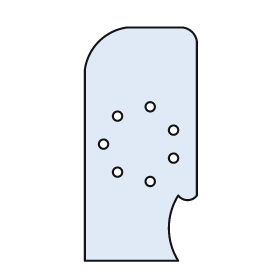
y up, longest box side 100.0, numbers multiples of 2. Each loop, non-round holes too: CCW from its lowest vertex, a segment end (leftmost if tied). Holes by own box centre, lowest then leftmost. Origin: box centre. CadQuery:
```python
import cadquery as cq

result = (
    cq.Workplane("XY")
    .moveTo(-24.0, -50.0)
    .lineTo(16.0, -50.0)
    .threePointArc((12.0, -36.0), (16.0, -22.0))
    .threePointArc((20.0, -24.0), (24.0, -22.0))
    .lineTo(24.0, 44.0)
    .threePointArc((22.0, 48.0), (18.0, 50.0))
    .lineTo(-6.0, 50.0)
    .threePointArc((-18.0, 44.0), (-24.0, 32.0))
    .close()
    .moveTo(4.0, -16.0)
    .circle(2.0)
    .moveTo(-10.0, -12.0)
    .circle(2.0)
    .moveTo(14.0, -6.0)
    .circle(2.0)
    .moveTo(-16.0, 0.0)
    .circle(2.0)
    .moveTo(14.0, 6.0)
    .circle(2.0)
    .moveTo(-10.0, 12.0)
    .circle(2.0)
    .moveTo(4.0, 16.0)
    .circle(2.0)
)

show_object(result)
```